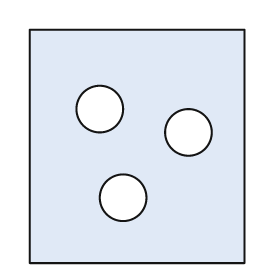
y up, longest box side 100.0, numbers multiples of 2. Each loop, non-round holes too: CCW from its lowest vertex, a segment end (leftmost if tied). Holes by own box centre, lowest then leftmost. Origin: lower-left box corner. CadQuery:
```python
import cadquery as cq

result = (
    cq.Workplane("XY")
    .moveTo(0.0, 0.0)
    .lineTo(92.0, 0.0)
    .lineTo(92.0, 100.0)
    .lineTo(0.0, 100.0)
    .close()
    .moveTo(40.0, 28.0)
    .circle(10.0)
    .moveTo(68.0, 56.0)
    .circle(10.0)
    .moveTo(30.0, 66.0)
    .circle(10.0)
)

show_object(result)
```